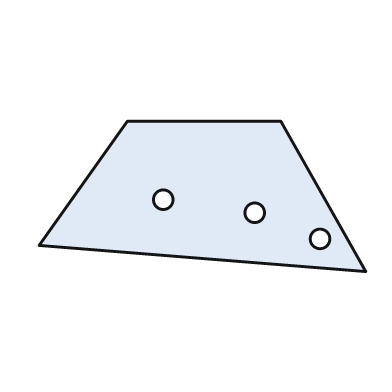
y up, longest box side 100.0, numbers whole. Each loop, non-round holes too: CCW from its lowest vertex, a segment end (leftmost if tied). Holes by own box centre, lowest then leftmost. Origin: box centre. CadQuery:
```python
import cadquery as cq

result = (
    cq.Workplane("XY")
    .moveTo(50.0, -23.0)
    .lineTo(24.0, 23.0)
    .lineTo(-23.0, 23.0)
    .lineTo(-50.0, -15.0)
    .close()
    .moveTo(36.0, -13.0)
    .circle(3.0)
    .moveTo(16.0, -5.0)
    .circle(3.0)
    .moveTo(-12.0, -1.0)
    .circle(3.0)
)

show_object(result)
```